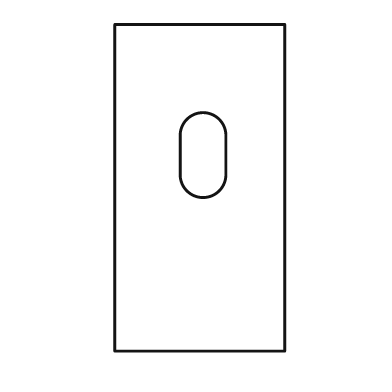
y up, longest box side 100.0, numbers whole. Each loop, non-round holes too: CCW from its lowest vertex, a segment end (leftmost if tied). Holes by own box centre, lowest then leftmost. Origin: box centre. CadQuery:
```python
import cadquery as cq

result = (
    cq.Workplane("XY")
    .moveTo(-26.0, -50.0)
    .lineTo(26.0, -50.0)
    .lineTo(26.0, 50.0)
    .lineTo(-26.0, 50.0)
    .close()
    .moveTo(-6.0, 4.0)
    .threePointArc((1.0, -3.0), (8.0, 4.0))
    .lineTo(8.0, 16.0)
    .threePointArc((1.0, 23.0), (-6.0, 16.0))
    .close()
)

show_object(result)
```